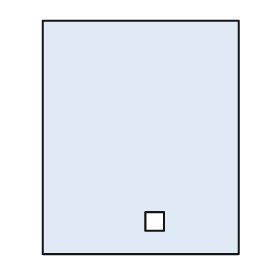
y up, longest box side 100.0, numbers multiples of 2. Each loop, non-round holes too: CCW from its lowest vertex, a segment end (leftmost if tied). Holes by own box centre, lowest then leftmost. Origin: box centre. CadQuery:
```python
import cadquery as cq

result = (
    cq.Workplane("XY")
    .moveTo(-42.0, -50.0)
    .lineTo(42.0, -50.0)
    .lineTo(42.0, 50.0)
    .lineTo(-42.0, 50.0)
    .close()
    .moveTo(2.0, -40.0)
    .lineTo(10.0, -40.0)
    .lineTo(10.0, -32.0)
    .lineTo(2.0, -32.0)
    .close()
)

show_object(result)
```